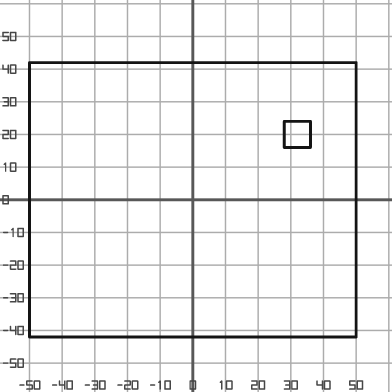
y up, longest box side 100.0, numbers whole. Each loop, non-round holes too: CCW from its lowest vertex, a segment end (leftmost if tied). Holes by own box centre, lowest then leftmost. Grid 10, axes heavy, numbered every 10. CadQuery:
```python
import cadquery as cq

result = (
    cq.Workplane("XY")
    .moveTo(-50.0, -42.0)
    .lineTo(50.0, -42.0)
    .lineTo(50.0, 42.0)
    .lineTo(-50.0, 42.0)
    .close()
    .moveTo(28.0, 16.0)
    .lineTo(36.0, 16.0)
    .lineTo(36.0, 24.0)
    .lineTo(28.0, 24.0)
    .close()
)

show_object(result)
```